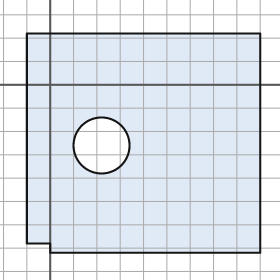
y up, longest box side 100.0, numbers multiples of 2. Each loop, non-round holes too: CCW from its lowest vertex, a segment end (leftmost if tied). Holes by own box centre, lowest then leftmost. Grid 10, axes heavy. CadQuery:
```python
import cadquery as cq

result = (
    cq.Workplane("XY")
    .moveTo(0.0, -72.0)
    .lineTo(90.0, -72.0)
    .lineTo(90.0, 22.0)
    .lineTo(-10.0, 22.0)
    .lineTo(-10.0, -68.0)
    .lineTo(0.0, -68.0)
    .close()
    .moveTo(22.0, -26.0)
    .circle(12.0)
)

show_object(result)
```